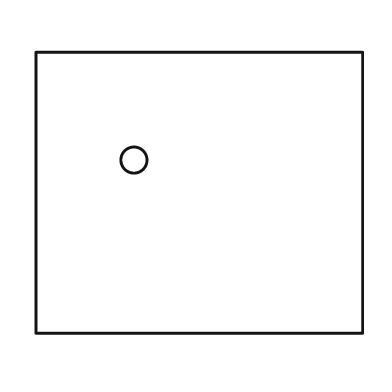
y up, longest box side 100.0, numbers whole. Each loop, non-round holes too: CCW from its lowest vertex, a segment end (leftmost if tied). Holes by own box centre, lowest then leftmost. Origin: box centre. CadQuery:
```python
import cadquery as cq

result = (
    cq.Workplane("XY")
    .moveTo(-50.0, -43.0)
    .lineTo(50.0, -43.0)
    .lineTo(50.0, 43.0)
    .lineTo(-50.0, 43.0)
    .close()
    .moveTo(-20.0, 10.0)
    .circle(4.0)
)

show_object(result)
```